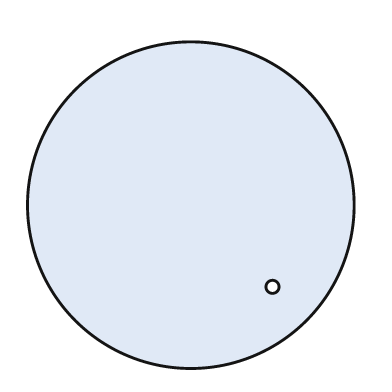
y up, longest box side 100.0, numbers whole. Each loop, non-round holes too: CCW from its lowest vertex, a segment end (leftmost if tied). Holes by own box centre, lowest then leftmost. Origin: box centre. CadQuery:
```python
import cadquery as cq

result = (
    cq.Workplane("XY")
    .moveTo(0.0, 0.0)
    .circle(50.0)
    .moveTo(25.0, -25.0)
    .circle(2.0)
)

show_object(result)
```